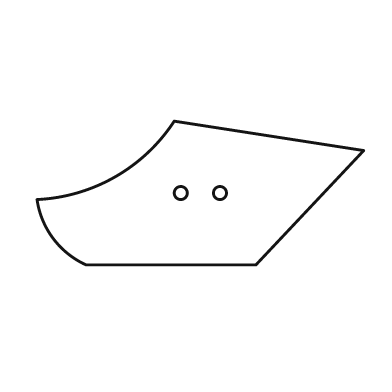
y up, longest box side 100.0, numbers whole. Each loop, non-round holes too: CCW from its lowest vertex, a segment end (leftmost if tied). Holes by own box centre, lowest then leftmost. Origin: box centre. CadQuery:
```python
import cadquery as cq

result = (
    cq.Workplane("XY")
    .moveTo(-35.0, -22.0)
    .lineTo(17.0, -22.0)
    .lineTo(50.0, 13.0)
    .lineTo(-8.0, 22.0)
    .threePointArc((-26.0, 5.0), (-50.0, -2.0))
    .threePointArc((-45.0, -14.0), (-35.0, -22.0))
    .close()
    .moveTo(-6.0, 0.0)
    .circle(2.0)
    .moveTo(6.0, 0.0)
    .circle(2.0)
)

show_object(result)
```